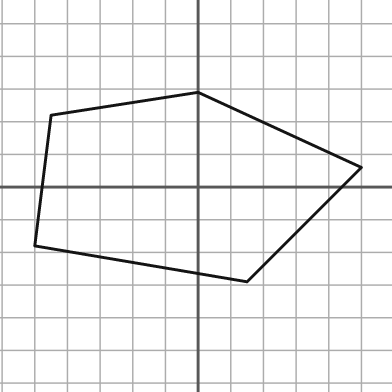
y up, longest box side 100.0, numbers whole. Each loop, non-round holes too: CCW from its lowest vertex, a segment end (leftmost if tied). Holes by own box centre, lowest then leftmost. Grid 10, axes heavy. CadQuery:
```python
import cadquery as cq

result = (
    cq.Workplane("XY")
    .moveTo(15.0, -29.0)
    .lineTo(50.0, 6.0)
    .lineTo(0.0, 29.0)
    .lineTo(-45.0, 22.0)
    .lineTo(-50.0, -18.0)
    .close()
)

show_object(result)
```